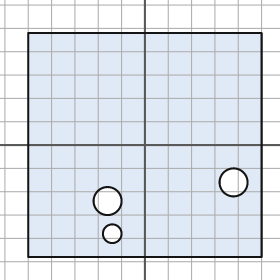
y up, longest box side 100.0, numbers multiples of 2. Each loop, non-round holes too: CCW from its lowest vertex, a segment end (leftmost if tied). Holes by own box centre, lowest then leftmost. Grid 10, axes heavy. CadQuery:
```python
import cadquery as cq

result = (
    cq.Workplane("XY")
    .moveTo(-50.0, -48.0)
    .lineTo(50.0, -48.0)
    .lineTo(50.0, 48.0)
    .lineTo(-50.0, 48.0)
    .close()
    .moveTo(-14.0, -38.0)
    .circle(4.0)
    .moveTo(-16.0, -24.0)
    .circle(6.0)
    .moveTo(38.0, -16.0)
    .circle(6.0)
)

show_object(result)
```